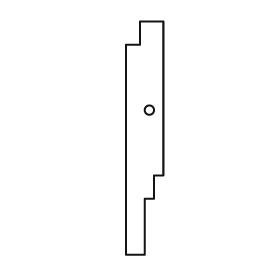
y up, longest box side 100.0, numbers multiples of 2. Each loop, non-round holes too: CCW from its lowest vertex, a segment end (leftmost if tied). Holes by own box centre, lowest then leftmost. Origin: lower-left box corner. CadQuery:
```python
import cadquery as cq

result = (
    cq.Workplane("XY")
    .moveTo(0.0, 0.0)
    .lineTo(8.0, 0.0)
    .lineTo(8.0, 24.0)
    .lineTo(12.0, 24.0)
    .lineTo(12.0, 34.0)
    .lineTo(16.0, 34.0)
    .lineTo(16.0, 100.0)
    .lineTo(6.0, 100.0)
    .lineTo(6.0, 90.0)
    .lineTo(0.0, 90.0)
    .close()
    .moveTo(10.0, 62.0)
    .circle(2.0)
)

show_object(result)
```